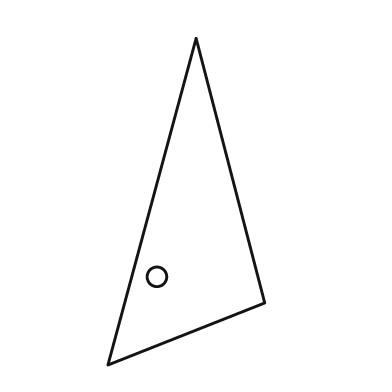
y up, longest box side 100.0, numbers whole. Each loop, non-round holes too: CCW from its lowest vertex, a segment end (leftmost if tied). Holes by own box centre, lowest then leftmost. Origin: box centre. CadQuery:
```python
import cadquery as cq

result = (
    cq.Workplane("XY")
    .moveTo(-24.0, -50.0)
    .lineTo(24.0, -31.0)
    .lineTo(3.0, 50.0)
    .close()
    .moveTo(-9.0, -23.0)
    .circle(3.0)
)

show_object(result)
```